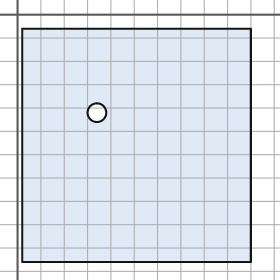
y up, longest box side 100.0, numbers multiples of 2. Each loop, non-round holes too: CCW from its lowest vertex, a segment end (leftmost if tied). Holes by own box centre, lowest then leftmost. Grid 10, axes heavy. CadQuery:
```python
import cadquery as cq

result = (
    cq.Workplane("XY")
    .moveTo(2.0, -106.0)
    .lineTo(100.0, -106.0)
    .lineTo(100.0, -6.0)
    .lineTo(2.0, -6.0)
    .close()
    .moveTo(34.0, -42.0)
    .circle(4.0)
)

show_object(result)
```